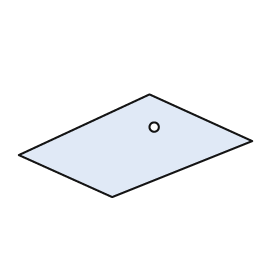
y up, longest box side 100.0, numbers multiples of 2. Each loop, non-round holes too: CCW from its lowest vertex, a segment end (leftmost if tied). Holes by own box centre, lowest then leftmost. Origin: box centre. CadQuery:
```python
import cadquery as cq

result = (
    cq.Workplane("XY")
    .moveTo(-10.0, -22.0)
    .lineTo(50.0, 2.0)
    .lineTo(6.0, 22.0)
    .lineTo(-50.0, -4.0)
    .close()
    .moveTo(8.0, 8.0)
    .circle(2.0)
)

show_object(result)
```